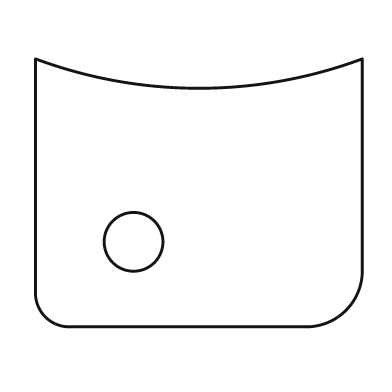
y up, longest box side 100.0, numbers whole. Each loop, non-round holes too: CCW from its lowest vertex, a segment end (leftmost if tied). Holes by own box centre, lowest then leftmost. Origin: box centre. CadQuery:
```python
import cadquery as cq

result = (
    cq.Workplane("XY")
    .moveTo(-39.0, -41.0)
    .lineTo(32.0, -41.0)
    .threePointArc((45.0, -36.0), (50.0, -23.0))
    .lineTo(50.0, 41.0)
    .threePointArc((0.0, 32.0), (-50.0, 41.0))
    .lineTo(-50.0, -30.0)
    .threePointArc((-47.0, -38.0), (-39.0, -41.0))
    .close()
    .moveTo(-20.0, -15.0)
    .circle(9.0)
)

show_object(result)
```